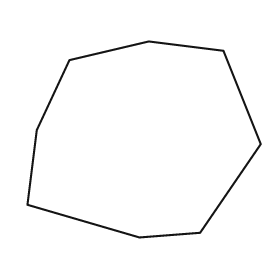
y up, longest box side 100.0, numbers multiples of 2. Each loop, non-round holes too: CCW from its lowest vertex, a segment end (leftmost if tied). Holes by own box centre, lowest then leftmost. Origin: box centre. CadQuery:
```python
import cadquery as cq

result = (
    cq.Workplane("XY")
    .moveTo(-2.0, -42.0)
    .lineTo(24.0, -40.0)
    .lineTo(50.0, -2.0)
    .lineTo(34.0, 38.0)
    .lineTo(2.0, 42.0)
    .lineTo(-32.0, 34.0)
    .lineTo(-46.0, 4.0)
    .lineTo(-50.0, -28.0)
    .close()
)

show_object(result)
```